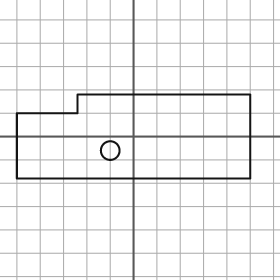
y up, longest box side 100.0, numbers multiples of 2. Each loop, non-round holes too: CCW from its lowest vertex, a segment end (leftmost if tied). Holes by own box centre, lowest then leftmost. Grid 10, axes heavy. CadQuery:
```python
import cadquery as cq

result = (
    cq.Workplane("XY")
    .moveTo(-50.0, -18.0)
    .lineTo(50.0, -18.0)
    .lineTo(50.0, 18.0)
    .lineTo(-24.0, 18.0)
    .lineTo(-24.0, 10.0)
    .lineTo(-50.0, 10.0)
    .close()
    .moveTo(-10.0, -6.0)
    .circle(4.0)
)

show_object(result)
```